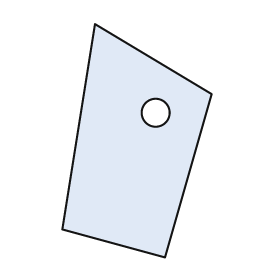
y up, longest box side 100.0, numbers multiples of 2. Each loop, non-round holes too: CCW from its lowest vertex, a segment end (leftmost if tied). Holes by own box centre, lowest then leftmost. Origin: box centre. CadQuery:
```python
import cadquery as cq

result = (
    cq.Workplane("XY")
    .moveTo(12.0, -50.0)
    .lineTo(32.0, 20.0)
    .lineTo(-18.0, 50.0)
    .lineTo(-32.0, -38.0)
    .close()
    .moveTo(8.0, 12.0)
    .circle(6.0)
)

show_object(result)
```